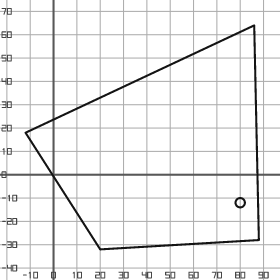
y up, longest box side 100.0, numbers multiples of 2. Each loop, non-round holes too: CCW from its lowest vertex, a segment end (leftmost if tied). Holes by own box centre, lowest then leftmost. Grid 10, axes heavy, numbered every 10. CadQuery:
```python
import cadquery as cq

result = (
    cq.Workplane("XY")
    .moveTo(20.0, -32.0)
    .lineTo(88.0, -28.0)
    .lineTo(86.0, 64.0)
    .lineTo(-12.0, 18.0)
    .close()
    .moveTo(80.0, -12.0)
    .circle(2.0)
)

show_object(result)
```